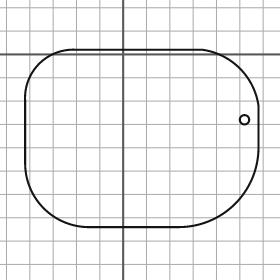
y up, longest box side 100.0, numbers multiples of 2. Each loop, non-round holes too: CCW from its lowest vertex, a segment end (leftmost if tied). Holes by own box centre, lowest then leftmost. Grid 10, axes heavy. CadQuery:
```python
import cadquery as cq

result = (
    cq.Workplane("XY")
    .moveTo(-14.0, -74.0)
    .lineTo(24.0, -74.0)
    .threePointArc((48.0, -64.0), (58.0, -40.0))
    .lineTo(58.0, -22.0)
    .threePointArc((50.0, -6.0), (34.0, 2.0))
    .lineTo(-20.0, 2.0)
    .threePointArc((-36.0, -4.0), (-42.0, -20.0))
    .lineTo(-42.0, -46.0)
    .threePointArc((-34.0, -66.0), (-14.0, -74.0))
    .close()
    .moveTo(52.0, -28.0)
    .circle(2.0)
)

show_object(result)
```